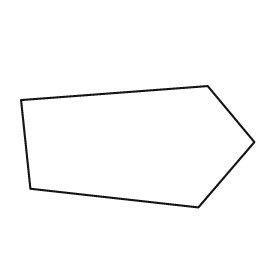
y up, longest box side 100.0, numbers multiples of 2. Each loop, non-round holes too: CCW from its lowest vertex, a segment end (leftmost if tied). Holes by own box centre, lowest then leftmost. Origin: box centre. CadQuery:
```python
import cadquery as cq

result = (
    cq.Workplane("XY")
    .moveTo(26.0, -26.0)
    .lineTo(50.0, 2.0)
    .lineTo(30.0, 26.0)
    .lineTo(-50.0, 20.0)
    .lineTo(-46.0, -18.0)
    .close()
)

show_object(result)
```